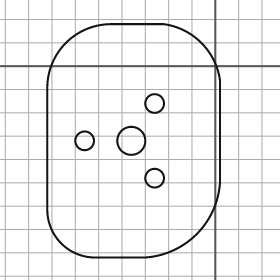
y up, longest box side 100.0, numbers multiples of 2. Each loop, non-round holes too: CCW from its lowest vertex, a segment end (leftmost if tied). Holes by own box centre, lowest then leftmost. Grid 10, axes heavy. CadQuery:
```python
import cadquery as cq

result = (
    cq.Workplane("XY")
    .moveTo(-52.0, -82.0)
    .lineTo(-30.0, -82.0)
    .threePointArc((-8.0, -72.0), (2.0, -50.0))
    .lineTo(2.0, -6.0)
    .threePointArc((-6.0, 10.0), (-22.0, 18.0))
    .lineTo(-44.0, 18.0)
    .threePointArc((-64.0, 10.0), (-72.0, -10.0))
    .lineTo(-72.0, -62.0)
    .threePointArc((-66.0, -76.0), (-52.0, -82.0))
    .close()
    .moveTo(-26.0, -48.0)
    .circle(4.0)
    .moveTo(-56.0, -32.0)
    .circle(4.0)
    .moveTo(-36.0, -32.0)
    .circle(6.0)
    .moveTo(-26.0, -16.0)
    .circle(4.0)
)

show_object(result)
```